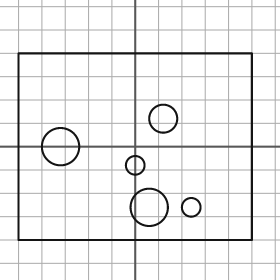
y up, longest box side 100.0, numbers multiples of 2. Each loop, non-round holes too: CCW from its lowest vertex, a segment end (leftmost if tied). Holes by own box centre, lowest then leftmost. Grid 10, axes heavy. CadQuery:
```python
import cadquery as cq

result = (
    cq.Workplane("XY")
    .moveTo(-50.0, -40.0)
    .lineTo(50.0, -40.0)
    .lineTo(50.0, 40.0)
    .lineTo(-50.0, 40.0)
    .close()
    .moveTo(6.0, -26.0)
    .circle(8.0)
    .moveTo(24.0, -26.0)
    .circle(4.0)
    .moveTo(0.0, -8.0)
    .circle(4.0)
    .moveTo(-32.0, 0.0)
    .circle(8.0)
    .moveTo(12.0, 12.0)
    .circle(6.0)
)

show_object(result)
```